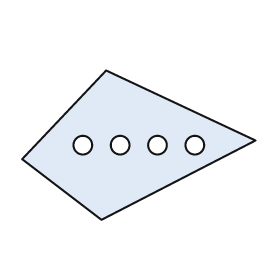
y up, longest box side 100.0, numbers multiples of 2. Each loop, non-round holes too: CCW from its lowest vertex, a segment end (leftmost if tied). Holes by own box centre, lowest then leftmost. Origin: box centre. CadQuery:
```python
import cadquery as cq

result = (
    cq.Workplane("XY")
    .moveTo(-16.0, -32.0)
    .lineTo(50.0, 2.0)
    .lineTo(-14.0, 32.0)
    .lineTo(-50.0, -6.0)
    .close()
    .moveTo(-24.0, 0.0)
    .circle(4.0)
    .moveTo(-8.0, 0.0)
    .circle(4.0)
    .moveTo(8.0, 0.0)
    .circle(4.0)
    .moveTo(24.0, 0.0)
    .circle(4.0)
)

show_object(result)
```